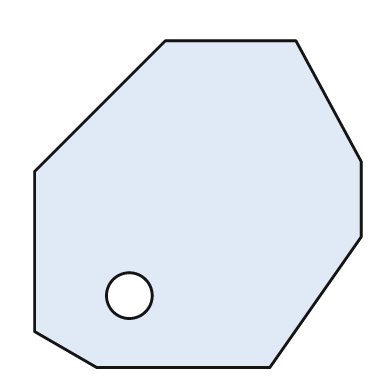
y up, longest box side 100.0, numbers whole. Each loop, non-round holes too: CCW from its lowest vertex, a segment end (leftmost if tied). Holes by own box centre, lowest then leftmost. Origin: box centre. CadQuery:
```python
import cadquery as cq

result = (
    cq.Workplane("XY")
    .moveTo(-31.0, -50.0)
    .lineTo(22.0, -50.0)
    .lineTo(50.0, -10.0)
    .lineTo(50.0, 13.0)
    .lineTo(30.0, 50.0)
    .lineTo(-10.0, 50.0)
    .lineTo(-50.0, 10.0)
    .lineTo(-50.0, -39.0)
    .close()
    .moveTo(-21.0, -28.0)
    .circle(7.0)
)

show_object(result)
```